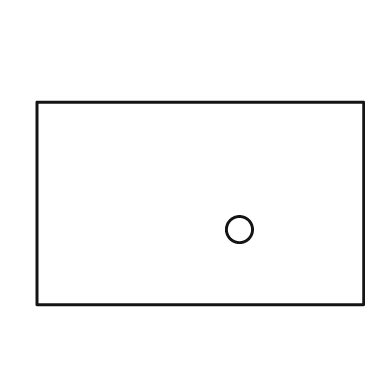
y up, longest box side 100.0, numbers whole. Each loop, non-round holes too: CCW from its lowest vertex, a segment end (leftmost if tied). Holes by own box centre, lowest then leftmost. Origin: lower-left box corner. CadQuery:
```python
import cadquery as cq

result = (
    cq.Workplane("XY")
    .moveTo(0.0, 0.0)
    .lineTo(100.0, 0.0)
    .lineTo(100.0, 62.0)
    .lineTo(0.0, 62.0)
    .close()
    .moveTo(62.0, 23.0)
    .circle(4.0)
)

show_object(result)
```